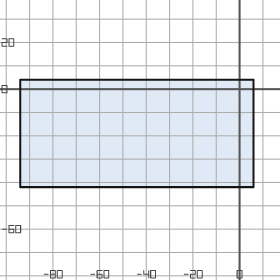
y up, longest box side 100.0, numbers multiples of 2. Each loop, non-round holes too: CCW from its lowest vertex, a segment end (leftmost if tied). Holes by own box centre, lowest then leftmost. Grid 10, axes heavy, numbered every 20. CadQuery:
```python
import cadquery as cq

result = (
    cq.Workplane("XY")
    .moveTo(-94.0, -42.0)
    .lineTo(6.0, -42.0)
    .lineTo(6.0, 4.0)
    .lineTo(-94.0, 4.0)
    .close()
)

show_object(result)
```